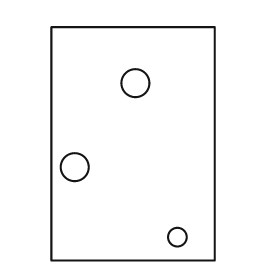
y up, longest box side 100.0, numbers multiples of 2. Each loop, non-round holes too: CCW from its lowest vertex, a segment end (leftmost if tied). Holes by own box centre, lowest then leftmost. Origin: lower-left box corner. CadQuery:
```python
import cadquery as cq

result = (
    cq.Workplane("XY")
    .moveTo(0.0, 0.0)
    .lineTo(70.0, 0.0)
    .lineTo(70.0, 100.0)
    .lineTo(0.0, 100.0)
    .close()
    .moveTo(54.0, 10.0)
    .circle(4.0)
    .moveTo(10.0, 40.0)
    .circle(6.0)
    .moveTo(36.0, 76.0)
    .circle(6.0)
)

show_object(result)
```